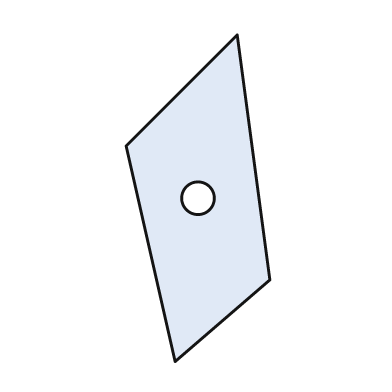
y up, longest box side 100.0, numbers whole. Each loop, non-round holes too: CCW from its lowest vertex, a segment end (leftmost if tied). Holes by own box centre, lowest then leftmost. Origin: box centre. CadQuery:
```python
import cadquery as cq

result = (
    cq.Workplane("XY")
    .moveTo(-7.0, -50.0)
    .lineTo(22.0, -25.0)
    .lineTo(12.0, 50.0)
    .lineTo(-22.0, 16.0)
    .close()
    .moveTo(0.0, 0.0)
    .circle(5.0)
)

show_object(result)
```